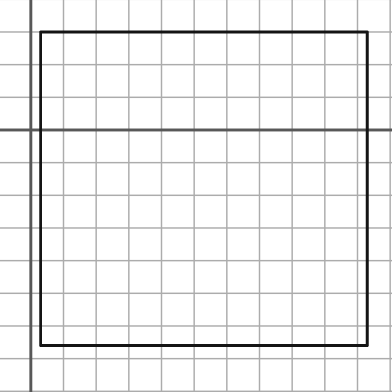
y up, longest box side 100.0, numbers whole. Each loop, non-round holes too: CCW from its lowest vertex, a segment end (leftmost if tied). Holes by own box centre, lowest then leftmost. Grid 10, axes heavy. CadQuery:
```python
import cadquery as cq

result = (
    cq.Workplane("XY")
    .moveTo(3.0, -66.0)
    .lineTo(103.0, -66.0)
    .lineTo(103.0, 30.0)
    .lineTo(3.0, 30.0)
    .close()
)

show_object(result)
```